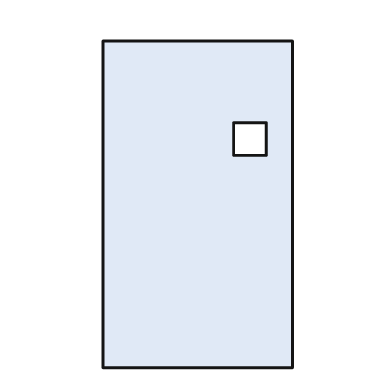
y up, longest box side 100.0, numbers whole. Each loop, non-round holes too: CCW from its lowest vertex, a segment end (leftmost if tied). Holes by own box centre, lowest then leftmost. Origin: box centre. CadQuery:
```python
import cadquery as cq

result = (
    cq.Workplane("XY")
    .moveTo(-29.0, -50.0)
    .lineTo(29.0, -50.0)
    .lineTo(29.0, 50.0)
    .lineTo(-29.0, 50.0)
    .close()
    .moveTo(11.0, 15.0)
    .lineTo(21.0, 15.0)
    .lineTo(21.0, 25.0)
    .lineTo(11.0, 25.0)
    .close()
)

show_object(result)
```